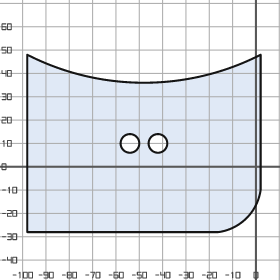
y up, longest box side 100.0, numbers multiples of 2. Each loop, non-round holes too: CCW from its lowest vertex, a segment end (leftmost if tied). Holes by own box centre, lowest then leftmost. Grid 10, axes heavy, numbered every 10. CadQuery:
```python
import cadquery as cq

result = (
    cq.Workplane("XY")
    .moveTo(-98.0, -28.0)
    .lineTo(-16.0, -28.0)
    .threePointArc((-4.0, -22.0), (2.0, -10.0))
    .lineTo(2.0, 48.0)
    .threePointArc((-48.0, 36.0), (-98.0, 48.0))
    .close()
    .moveTo(-54.0, 10.0)
    .circle(4.0)
    .moveTo(-42.0, 10.0)
    .circle(4.0)
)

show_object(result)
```